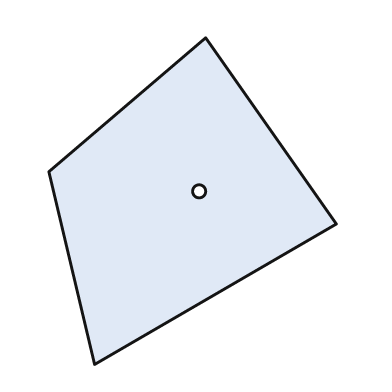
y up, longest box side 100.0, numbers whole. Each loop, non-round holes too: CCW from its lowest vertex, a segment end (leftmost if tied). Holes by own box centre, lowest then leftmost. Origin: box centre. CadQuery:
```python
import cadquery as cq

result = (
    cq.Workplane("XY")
    .moveTo(-30.0, -50.0)
    .lineTo(44.0, -7.0)
    .lineTo(4.0, 50.0)
    .lineTo(-44.0, 9.0)
    .close()
    .moveTo(2.0, 3.0)
    .circle(2.0)
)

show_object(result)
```